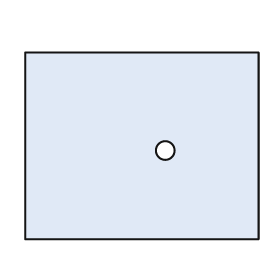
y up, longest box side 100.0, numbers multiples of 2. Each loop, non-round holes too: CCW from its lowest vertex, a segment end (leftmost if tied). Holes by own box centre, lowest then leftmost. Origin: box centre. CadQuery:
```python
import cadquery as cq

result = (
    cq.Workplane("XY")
    .moveTo(-50.0, -40.0)
    .lineTo(50.0, -40.0)
    .lineTo(50.0, 40.0)
    .lineTo(-50.0, 40.0)
    .close()
    .moveTo(10.0, -2.0)
    .circle(4.0)
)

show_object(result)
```